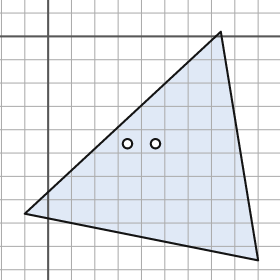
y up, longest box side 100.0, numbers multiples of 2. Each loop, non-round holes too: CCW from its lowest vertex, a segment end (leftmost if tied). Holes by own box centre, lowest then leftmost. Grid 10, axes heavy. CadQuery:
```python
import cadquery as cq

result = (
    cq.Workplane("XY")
    .moveTo(90.0, -96.0)
    .lineTo(74.0, 2.0)
    .lineTo(-10.0, -76.0)
    .close()
    .moveTo(34.0, -46.0)
    .circle(2.0)
    .moveTo(46.0, -46.0)
    .circle(2.0)
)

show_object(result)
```